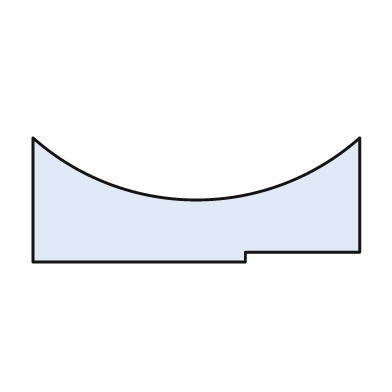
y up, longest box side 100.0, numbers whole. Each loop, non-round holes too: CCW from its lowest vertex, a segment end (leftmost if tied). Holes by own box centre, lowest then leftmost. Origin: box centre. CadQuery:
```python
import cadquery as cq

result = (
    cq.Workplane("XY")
    .moveTo(-50.0, -19.0)
    .lineTo(15.0, -19.0)
    .lineTo(15.0, -16.0)
    .lineTo(50.0, -16.0)
    .lineTo(50.0, 19.0)
    .threePointArc((0.0, 0.0), (-50.0, 19.0))
    .close()
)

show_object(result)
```